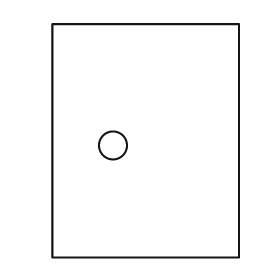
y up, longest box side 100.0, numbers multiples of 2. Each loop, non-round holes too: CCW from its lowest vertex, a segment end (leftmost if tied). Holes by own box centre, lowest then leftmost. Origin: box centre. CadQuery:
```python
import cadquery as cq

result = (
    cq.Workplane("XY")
    .moveTo(-40.0, -50.0)
    .lineTo(40.0, -50.0)
    .lineTo(40.0, 50.0)
    .lineTo(-40.0, 50.0)
    .close()
    .moveTo(-14.0, -2.0)
    .circle(6.0)
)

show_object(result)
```